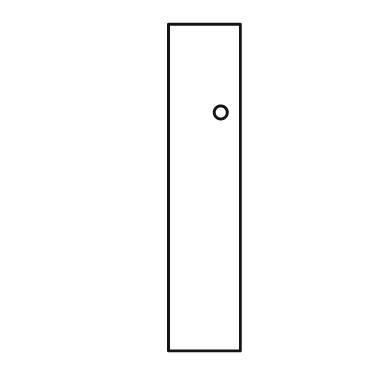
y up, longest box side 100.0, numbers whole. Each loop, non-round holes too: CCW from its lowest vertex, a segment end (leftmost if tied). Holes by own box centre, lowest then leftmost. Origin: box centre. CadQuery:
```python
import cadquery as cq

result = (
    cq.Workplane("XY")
    .moveTo(-11.0, -50.0)
    .lineTo(11.0, -50.0)
    .lineTo(11.0, 50.0)
    .lineTo(-11.0, 50.0)
    .close()
    .moveTo(5.0, 23.0)
    .circle(2.0)
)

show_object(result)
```